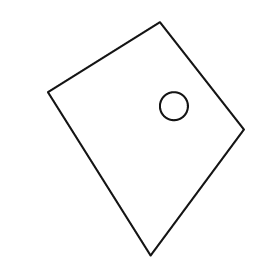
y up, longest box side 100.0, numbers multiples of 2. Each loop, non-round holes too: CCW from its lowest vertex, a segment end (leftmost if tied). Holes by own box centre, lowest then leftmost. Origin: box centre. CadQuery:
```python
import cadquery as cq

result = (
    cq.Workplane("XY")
    .moveTo(2.0, -50.0)
    .lineTo(42.0, 4.0)
    .lineTo(6.0, 50.0)
    .lineTo(-42.0, 20.0)
    .close()
    .moveTo(12.0, 14.0)
    .circle(6.0)
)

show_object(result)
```